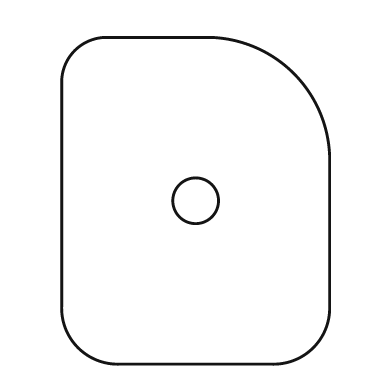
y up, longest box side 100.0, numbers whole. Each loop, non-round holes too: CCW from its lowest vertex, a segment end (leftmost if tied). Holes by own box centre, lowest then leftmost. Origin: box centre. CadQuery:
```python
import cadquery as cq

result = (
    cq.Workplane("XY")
    .moveTo(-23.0, -50.0)
    .lineTo(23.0, -50.0)
    .threePointArc((36.0, -45.0), (41.0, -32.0))
    .lineTo(41.0, 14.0)
    .threePointArc((30.0, 39.0), (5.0, 50.0))
    .lineTo(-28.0, 50.0)
    .threePointArc((-37.0, 46.0), (-41.0, 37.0))
    .lineTo(-41.0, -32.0)
    .threePointArc((-36.0, -45.0), (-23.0, -50.0))
    .close()
    .moveTo(0.0, 0.0)
    .circle(7.0)
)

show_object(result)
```